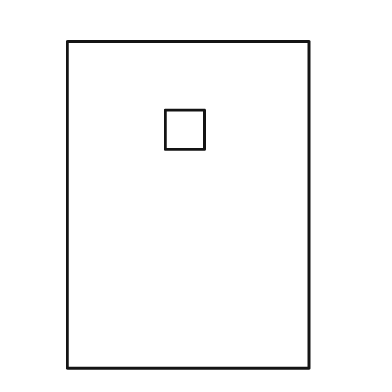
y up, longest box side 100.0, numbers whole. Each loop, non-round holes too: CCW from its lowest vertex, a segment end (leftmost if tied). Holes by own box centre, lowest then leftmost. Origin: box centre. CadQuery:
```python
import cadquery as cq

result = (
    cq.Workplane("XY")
    .moveTo(-37.0, -50.0)
    .lineTo(37.0, -50.0)
    .lineTo(37.0, 50.0)
    .lineTo(-37.0, 50.0)
    .close()
    .moveTo(-7.0, 17.0)
    .lineTo(5.0, 17.0)
    .lineTo(5.0, 29.0)
    .lineTo(-7.0, 29.0)
    .close()
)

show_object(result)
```